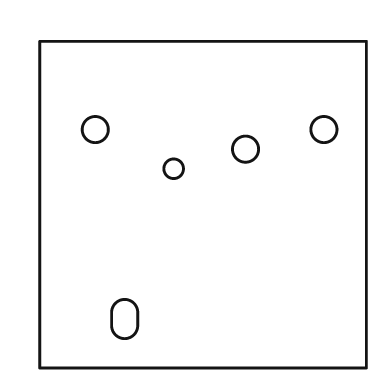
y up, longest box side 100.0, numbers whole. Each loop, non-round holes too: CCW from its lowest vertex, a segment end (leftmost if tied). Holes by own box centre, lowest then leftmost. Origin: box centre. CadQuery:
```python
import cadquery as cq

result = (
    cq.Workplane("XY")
    .moveTo(-50.0, -50.0)
    .lineTo(50.0, -50.0)
    .lineTo(50.0, 50.0)
    .lineTo(-50.0, 50.0)
    .close()
    .moveTo(-28.0, -37.0)
    .threePointArc((-24.0, -41.0), (-20.0, -37.0))
    .lineTo(-20.0, -33.0)
    .threePointArc((-24.0, -29.0), (-28.0, -33.0))
    .close()
    .moveTo(-9.0, 11.0)
    .circle(3.0)
    .moveTo(13.0, 17.0)
    .circle(4.0)
    .moveTo(-33.0, 23.0)
    .circle(4.0)
    .moveTo(37.0, 23.0)
    .circle(4.0)
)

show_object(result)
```